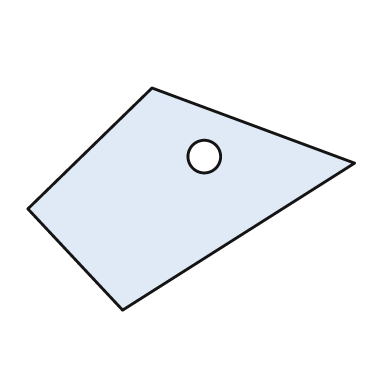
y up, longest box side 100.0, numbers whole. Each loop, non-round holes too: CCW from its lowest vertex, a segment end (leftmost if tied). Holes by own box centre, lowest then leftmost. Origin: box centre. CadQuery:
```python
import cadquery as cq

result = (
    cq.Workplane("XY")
    .moveTo(-21.0, -34.0)
    .lineTo(50.0, 11.0)
    .lineTo(-12.0, 34.0)
    .lineTo(-50.0, -3.0)
    .close()
    .moveTo(4.0, 13.0)
    .circle(5.0)
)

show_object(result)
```